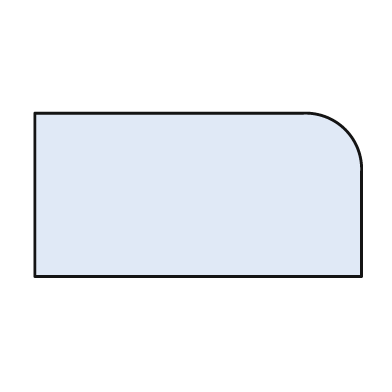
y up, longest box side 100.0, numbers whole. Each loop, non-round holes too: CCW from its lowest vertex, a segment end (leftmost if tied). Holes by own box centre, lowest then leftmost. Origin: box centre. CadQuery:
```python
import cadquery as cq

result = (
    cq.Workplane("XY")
    .moveTo(-50.0, -25.0)
    .lineTo(50.0, -25.0)
    .lineTo(50.0, 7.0)
    .threePointArc((45.0, 20.0), (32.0, 25.0))
    .lineTo(-50.0, 25.0)
    .close()
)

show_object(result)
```